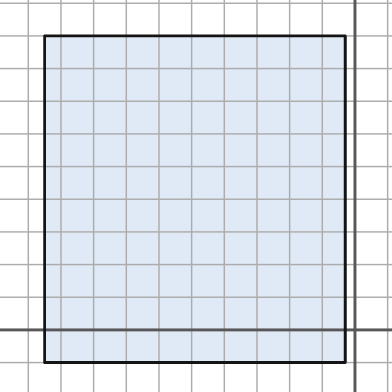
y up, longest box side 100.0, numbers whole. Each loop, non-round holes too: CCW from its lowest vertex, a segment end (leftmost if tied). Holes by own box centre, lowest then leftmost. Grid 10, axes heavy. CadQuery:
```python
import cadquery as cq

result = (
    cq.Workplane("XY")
    .moveTo(-95.0, -10.0)
    .lineTo(-3.0, -10.0)
    .lineTo(-3.0, 90.0)
    .lineTo(-95.0, 90.0)
    .close()
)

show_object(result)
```